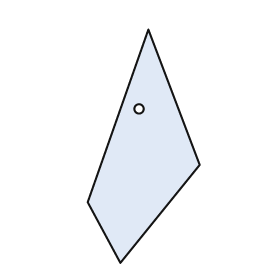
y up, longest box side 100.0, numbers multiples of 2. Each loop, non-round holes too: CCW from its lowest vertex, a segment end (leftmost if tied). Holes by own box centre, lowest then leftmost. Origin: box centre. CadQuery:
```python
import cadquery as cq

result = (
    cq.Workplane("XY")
    .moveTo(-10.0, -50.0)
    .lineTo(24.0, -8.0)
    .lineTo(2.0, 50.0)
    .lineTo(-24.0, -24.0)
    .close()
    .moveTo(-2.0, 16.0)
    .circle(2.0)
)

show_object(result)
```